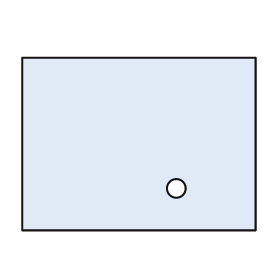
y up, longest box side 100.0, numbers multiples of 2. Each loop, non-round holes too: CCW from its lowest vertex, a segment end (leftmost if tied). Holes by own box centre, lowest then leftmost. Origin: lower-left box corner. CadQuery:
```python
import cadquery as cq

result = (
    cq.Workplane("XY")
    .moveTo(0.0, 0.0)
    .lineTo(100.0, 0.0)
    .lineTo(100.0, 74.0)
    .lineTo(0.0, 74.0)
    .close()
    .moveTo(66.0, 18.0)
    .circle(4.0)
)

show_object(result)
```